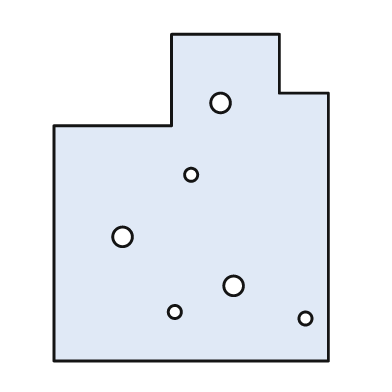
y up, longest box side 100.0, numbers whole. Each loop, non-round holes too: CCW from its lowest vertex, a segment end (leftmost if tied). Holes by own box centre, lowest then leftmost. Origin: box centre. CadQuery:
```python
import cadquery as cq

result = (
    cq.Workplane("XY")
    .moveTo(-42.0, -50.0)
    .lineTo(42.0, -50.0)
    .lineTo(42.0, 32.0)
    .lineTo(27.0, 32.0)
    .lineTo(27.0, 50.0)
    .lineTo(-6.0, 50.0)
    .lineTo(-6.0, 22.0)
    .lineTo(-42.0, 22.0)
    .close()
    .moveTo(35.0, -37.0)
    .circle(2.0)
    .moveTo(-5.0, -35.0)
    .circle(2.0)
    .moveTo(13.0, -27.0)
    .circle(3.0)
    .moveTo(-21.0, -12.0)
    .circle(3.0)
    .moveTo(0.0, 7.0)
    .circle(2.0)
    .moveTo(9.0, 29.0)
    .circle(3.0)
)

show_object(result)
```